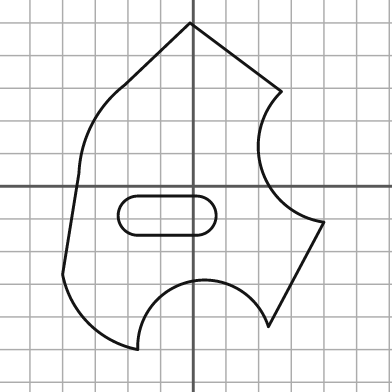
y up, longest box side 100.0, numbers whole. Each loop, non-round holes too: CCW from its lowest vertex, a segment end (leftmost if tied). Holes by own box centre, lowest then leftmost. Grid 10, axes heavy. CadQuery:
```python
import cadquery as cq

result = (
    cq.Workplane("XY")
    .moveTo(-17.0, -50.0)
    .threePointArc((0.0, -29.0), (23.0, -43.0))
    .lineTo(40.0, -11.0)
    .threePointArc((21.0, 5.0), (27.0, 29.0))
    .lineTo(-1.0, 50.0)
    .lineTo(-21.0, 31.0)
    .threePointArc((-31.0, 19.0), (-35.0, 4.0))
    .lineTo(-40.0, -27.0)
    .threePointArc((-32.0, -42.0), (-17.0, -50.0))
    .close()
    .moveTo(-17.0, -15.0)
    .lineTo(1.0, -15.0)
    .threePointArc((7.0, -9.0), (1.0, -3.0))
    .lineTo(-17.0, -3.0)
    .threePointArc((-23.0, -9.0), (-17.0, -15.0))
    .close()
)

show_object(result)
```